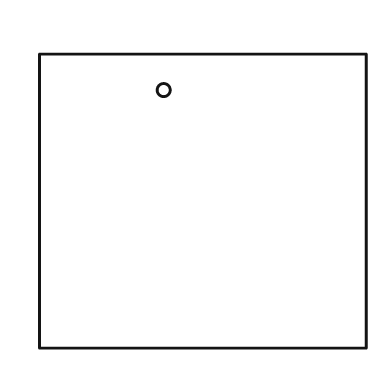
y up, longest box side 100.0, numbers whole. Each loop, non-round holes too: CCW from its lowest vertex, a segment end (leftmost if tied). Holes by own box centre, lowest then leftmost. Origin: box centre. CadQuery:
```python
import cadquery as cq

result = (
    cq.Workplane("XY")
    .moveTo(-50.0, -45.0)
    .lineTo(50.0, -45.0)
    .lineTo(50.0, 45.0)
    .lineTo(-50.0, 45.0)
    .close()
    .moveTo(-12.0, 34.0)
    .circle(2.0)
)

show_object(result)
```